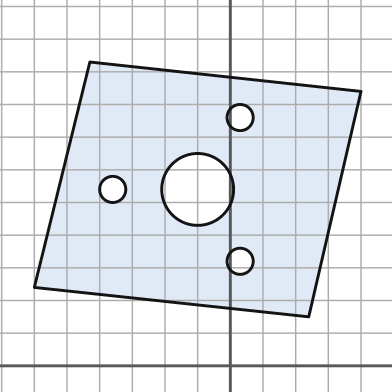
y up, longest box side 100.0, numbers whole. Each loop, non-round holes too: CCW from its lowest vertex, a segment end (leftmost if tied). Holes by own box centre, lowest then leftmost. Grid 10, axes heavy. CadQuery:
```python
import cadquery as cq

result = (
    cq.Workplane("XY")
    .moveTo(24.0, 15.0)
    .lineTo(40.0, 84.0)
    .lineTo(-43.0, 93.0)
    .lineTo(-60.0, 24.0)
    .close()
    .moveTo(3.0, 32.0)
    .circle(4.0)
    .moveTo(-36.0, 54.0)
    .circle(4.0)
    .moveTo(-10.0, 54.0)
    .circle(11.0)
    .moveTo(3.0, 76.0)
    .circle(4.0)
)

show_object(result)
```